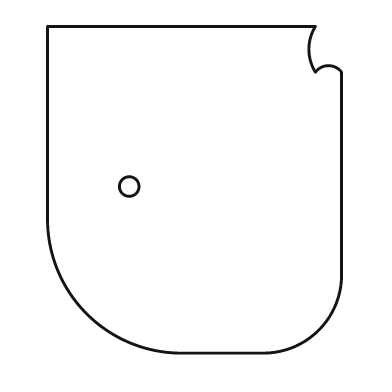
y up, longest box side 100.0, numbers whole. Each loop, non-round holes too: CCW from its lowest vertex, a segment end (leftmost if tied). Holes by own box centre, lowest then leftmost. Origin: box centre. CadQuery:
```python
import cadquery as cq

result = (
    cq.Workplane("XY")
    .moveTo(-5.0, -50.0)
    .lineTo(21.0, -50.0)
    .threePointArc((38.0, -43.0), (45.0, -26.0))
    .lineTo(45.0, 36.0)
    .threePointArc((41.0, 38.0), (37.0, 36.0))
    .threePointArc((35.0, 43.0), (37.0, 50.0))
    .lineTo(-45.0, 50.0)
    .lineTo(-45.0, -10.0)
    .threePointArc((-33.0, -38.0), (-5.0, -50.0))
    .close()
    .moveTo(-20.0, 1.0)
    .circle(3.0)
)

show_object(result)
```